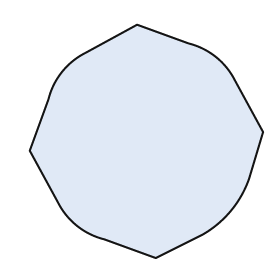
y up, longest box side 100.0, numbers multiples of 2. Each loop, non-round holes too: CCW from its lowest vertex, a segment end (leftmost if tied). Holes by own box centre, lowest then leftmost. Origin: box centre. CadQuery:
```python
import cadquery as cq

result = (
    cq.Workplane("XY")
    .moveTo(4.0, -50.0)
    .lineTo(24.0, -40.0)
    .threePointArc((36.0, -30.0), (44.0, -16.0))
    .lineTo(50.0, 4.0)
    .lineTo(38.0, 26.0)
    .threePointArc((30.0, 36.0), (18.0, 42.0))
    .lineTo(-4.0, 50.0)
    .lineTo(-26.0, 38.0)
    .threePointArc((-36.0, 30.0), (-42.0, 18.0))
    .lineTo(-50.0, -4.0)
    .lineTo(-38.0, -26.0)
    .threePointArc((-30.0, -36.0), (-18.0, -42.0))
    .close()
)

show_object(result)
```